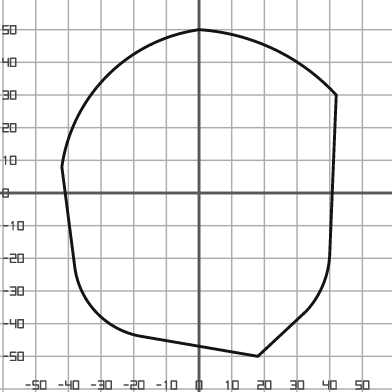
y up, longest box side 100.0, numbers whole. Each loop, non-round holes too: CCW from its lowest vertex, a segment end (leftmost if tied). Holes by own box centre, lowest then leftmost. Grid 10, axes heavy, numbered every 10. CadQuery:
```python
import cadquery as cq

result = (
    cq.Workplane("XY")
    .moveTo(18.0, -50.0)
    .lineTo(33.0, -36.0)
    .threePointArc((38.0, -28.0), (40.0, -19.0))
    .lineTo(42.0, 30.0)
    .threePointArc((23.0, 44.0), (0.0, 50.0))
    .threePointArc((-28.0, 36.0), (-42.0, 8.0))
    .lineTo(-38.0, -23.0)
    .threePointArc((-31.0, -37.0), (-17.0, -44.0))
    .close()
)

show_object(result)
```